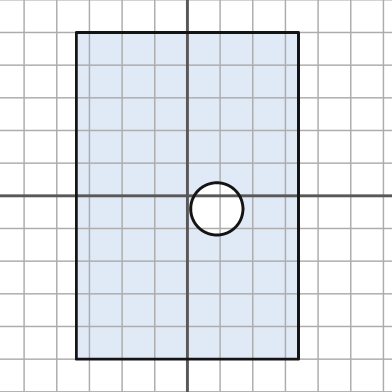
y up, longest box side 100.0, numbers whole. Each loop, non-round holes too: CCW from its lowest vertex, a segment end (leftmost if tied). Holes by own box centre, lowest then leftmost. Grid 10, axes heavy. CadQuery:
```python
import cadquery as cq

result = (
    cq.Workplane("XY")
    .moveTo(-34.0, -50.0)
    .lineTo(34.0, -50.0)
    .lineTo(34.0, 50.0)
    .lineTo(-34.0, 50.0)
    .close()
    .moveTo(9.0, -4.0)
    .circle(8.0)
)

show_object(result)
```